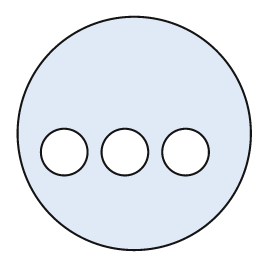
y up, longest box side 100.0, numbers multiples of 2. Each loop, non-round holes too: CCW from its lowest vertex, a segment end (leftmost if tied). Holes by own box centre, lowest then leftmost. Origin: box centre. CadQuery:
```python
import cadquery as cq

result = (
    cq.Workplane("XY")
    .moveTo(0.0, 0.0)
    .circle(50.0)
    .moveTo(-30.0, -8.0)
    .circle(10.0)
    .moveTo(-4.0, -8.0)
    .circle(10.0)
    .moveTo(22.0, -8.0)
    .circle(10.0)
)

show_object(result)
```